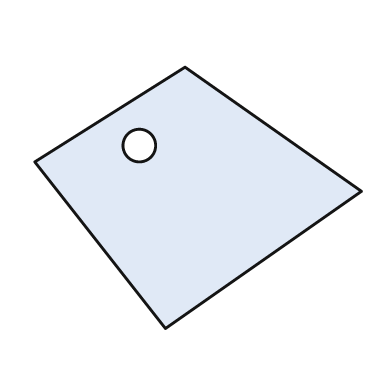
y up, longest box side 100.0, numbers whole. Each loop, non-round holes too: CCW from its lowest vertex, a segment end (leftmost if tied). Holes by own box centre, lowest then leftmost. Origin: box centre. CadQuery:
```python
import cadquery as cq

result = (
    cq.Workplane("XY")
    .moveTo(-10.0, -40.0)
    .lineTo(50.0, 2.0)
    .lineTo(-4.0, 40.0)
    .lineTo(-50.0, 11.0)
    .close()
    .moveTo(-18.0, 16.0)
    .circle(5.0)
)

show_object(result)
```